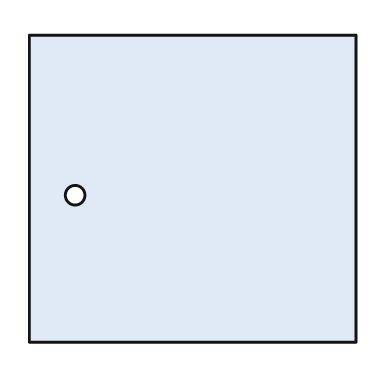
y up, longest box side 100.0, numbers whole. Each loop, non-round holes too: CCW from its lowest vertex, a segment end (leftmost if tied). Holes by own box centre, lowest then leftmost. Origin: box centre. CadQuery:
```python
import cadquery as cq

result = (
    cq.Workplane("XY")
    .moveTo(-50.0, -47.0)
    .lineTo(50.0, -47.0)
    .lineTo(50.0, 47.0)
    .lineTo(-50.0, 47.0)
    .close()
    .moveTo(-36.0, -2.0)
    .circle(3.0)
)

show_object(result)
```